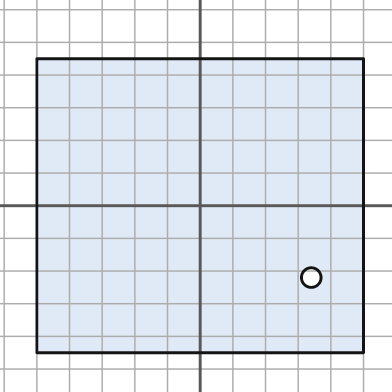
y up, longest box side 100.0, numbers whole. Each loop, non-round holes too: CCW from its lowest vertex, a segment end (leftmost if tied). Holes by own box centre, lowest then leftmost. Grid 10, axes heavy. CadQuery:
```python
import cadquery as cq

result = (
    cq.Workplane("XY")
    .moveTo(-50.0, -45.0)
    .lineTo(50.0, -45.0)
    .lineTo(50.0, 45.0)
    .lineTo(-50.0, 45.0)
    .close()
    .moveTo(34.0, -22.0)
    .circle(3.0)
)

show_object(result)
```